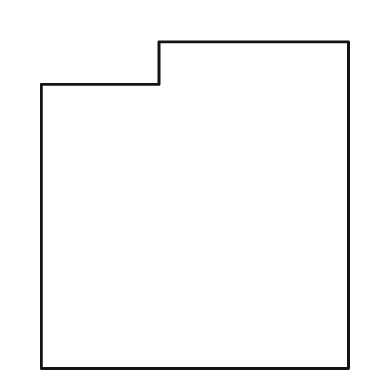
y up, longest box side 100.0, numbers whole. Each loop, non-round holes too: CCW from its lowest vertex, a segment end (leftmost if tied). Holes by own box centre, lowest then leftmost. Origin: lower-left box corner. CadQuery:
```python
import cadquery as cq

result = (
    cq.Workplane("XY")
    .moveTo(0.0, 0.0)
    .lineTo(94.0, 0.0)
    .lineTo(94.0, 100.0)
    .lineTo(36.0, 100.0)
    .lineTo(36.0, 87.0)
    .lineTo(0.0, 87.0)
    .close()
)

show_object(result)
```